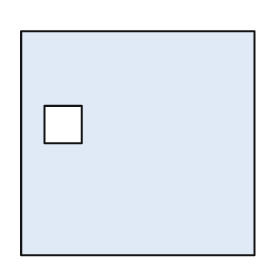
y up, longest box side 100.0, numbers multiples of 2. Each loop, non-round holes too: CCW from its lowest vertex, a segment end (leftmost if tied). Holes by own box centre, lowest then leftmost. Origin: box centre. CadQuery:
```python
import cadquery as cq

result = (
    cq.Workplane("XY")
    .moveTo(-50.0, -48.0)
    .lineTo(50.0, -48.0)
    .lineTo(50.0, 48.0)
    .lineTo(-50.0, 48.0)
    .close()
    .moveTo(-40.0, 0.0)
    .lineTo(-24.0, 0.0)
    .lineTo(-24.0, 16.0)
    .lineTo(-40.0, 16.0)
    .close()
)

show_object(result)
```